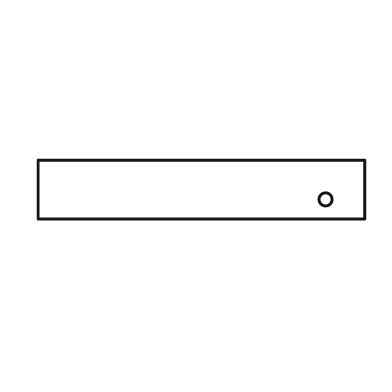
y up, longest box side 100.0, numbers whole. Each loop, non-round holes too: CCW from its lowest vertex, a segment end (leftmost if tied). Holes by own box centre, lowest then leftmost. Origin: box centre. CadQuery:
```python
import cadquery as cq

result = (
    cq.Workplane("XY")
    .moveTo(-50.0, -9.0)
    .lineTo(50.0, -9.0)
    .lineTo(50.0, 9.0)
    .lineTo(-50.0, 9.0)
    .close()
    .moveTo(38.0, -3.0)
    .circle(2.0)
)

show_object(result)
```